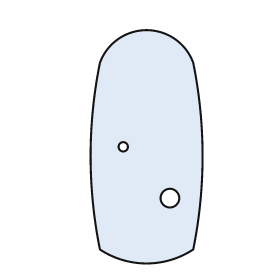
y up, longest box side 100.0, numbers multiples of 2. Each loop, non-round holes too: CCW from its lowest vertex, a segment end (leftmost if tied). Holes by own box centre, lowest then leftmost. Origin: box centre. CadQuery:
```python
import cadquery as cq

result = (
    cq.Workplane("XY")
    .moveTo(-20.0, -44.0)
    .threePointArc((0.0, -50.0), (20.0, -44.0))
    .threePointArc((24.0, -4.0), (20.0, 36.0))
    .threePointArc((0.0, 50.0), (-20.0, 36.0))
    .threePointArc((-24.0, -4.0), (-20.0, -44.0))
    .close()
    .moveTo(10.0, -22.0)
    .circle(4.0)
    .moveTo(-10.0, 0.0)
    .circle(2.0)
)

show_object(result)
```